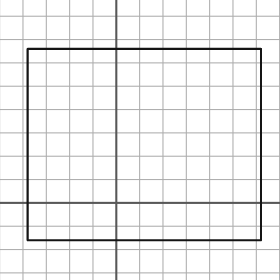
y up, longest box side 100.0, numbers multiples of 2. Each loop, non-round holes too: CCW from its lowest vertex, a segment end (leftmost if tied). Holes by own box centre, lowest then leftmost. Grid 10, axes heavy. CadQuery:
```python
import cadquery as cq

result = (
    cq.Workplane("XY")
    .moveTo(-38.0, -16.0)
    .lineTo(62.0, -16.0)
    .lineTo(62.0, 66.0)
    .lineTo(-38.0, 66.0)
    .close()
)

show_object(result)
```